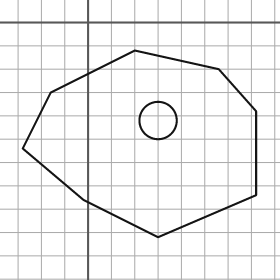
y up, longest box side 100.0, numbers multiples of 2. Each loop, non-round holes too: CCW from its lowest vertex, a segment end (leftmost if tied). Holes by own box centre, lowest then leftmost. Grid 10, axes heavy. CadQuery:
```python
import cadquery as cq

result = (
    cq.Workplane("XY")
    .moveTo(30.0, -92.0)
    .lineTo(72.0, -74.0)
    .lineTo(72.0, -38.0)
    .lineTo(56.0, -20.0)
    .lineTo(20.0, -12.0)
    .lineTo(-16.0, -30.0)
    .lineTo(-28.0, -54.0)
    .lineTo(-2.0, -76.0)
    .close()
    .moveTo(30.0, -42.0)
    .circle(8.0)
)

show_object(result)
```